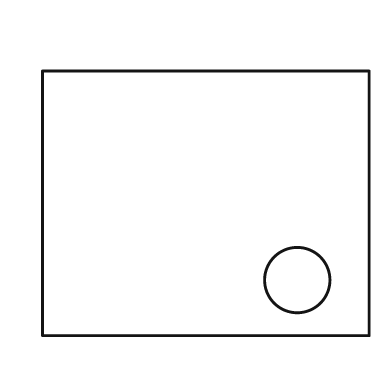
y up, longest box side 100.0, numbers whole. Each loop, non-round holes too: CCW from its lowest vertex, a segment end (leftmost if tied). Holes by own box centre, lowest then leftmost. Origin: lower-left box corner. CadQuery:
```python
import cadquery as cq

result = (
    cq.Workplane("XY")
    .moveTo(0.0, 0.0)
    .lineTo(100.0, 0.0)
    .lineTo(100.0, 81.0)
    .lineTo(0.0, 81.0)
    .close()
    .moveTo(78.0, 17.0)
    .circle(10.0)
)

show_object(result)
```